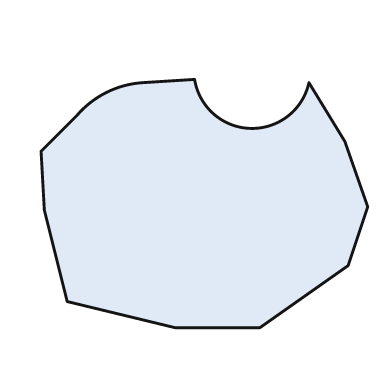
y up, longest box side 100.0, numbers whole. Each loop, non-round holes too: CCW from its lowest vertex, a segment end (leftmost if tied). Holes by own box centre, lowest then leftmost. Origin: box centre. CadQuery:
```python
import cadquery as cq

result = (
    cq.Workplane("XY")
    .moveTo(-9.0, -38.0)
    .lineTo(17.0, -38.0)
    .lineTo(44.0, -19.0)
    .lineTo(50.0, -1.0)
    .lineTo(43.0, 19.0)
    .lineTo(32.0, 37.0)
    .threePointArc((14.0, 23.0), (-3.0, 38.0))
    .lineTo(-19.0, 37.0)
    .threePointArc((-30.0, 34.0), (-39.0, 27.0))
    .lineTo(-50.0, 16.0)
    .lineTo(-49.0, -2.0)
    .lineTo(-42.0, -30.0)
    .close()
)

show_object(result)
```